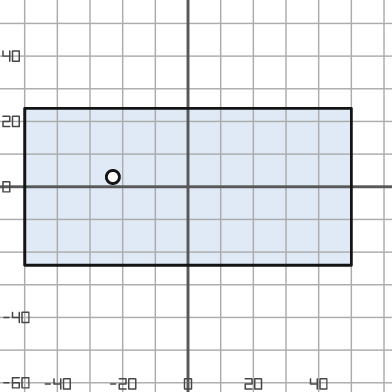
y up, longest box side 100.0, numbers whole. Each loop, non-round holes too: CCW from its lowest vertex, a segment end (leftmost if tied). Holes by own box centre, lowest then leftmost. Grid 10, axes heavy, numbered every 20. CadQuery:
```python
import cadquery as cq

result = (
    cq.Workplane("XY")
    .moveTo(-50.0, -24.0)
    .lineTo(50.0, -24.0)
    .lineTo(50.0, 24.0)
    .lineTo(-50.0, 24.0)
    .close()
    .moveTo(-23.0, 3.0)
    .circle(2.0)
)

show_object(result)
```